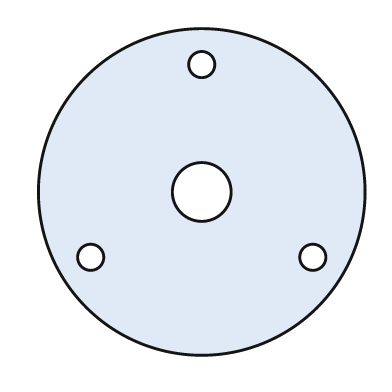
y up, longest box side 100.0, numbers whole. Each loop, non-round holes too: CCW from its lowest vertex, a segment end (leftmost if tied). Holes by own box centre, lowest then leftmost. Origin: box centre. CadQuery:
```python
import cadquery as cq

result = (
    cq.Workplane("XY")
    .moveTo(0.0, 0.0)
    .circle(50.0)
    .moveTo(-34.0, -20.0)
    .circle(4.0)
    .moveTo(34.0, -20.0)
    .circle(4.0)
    .moveTo(0.0, 0.0)
    .circle(9.0)
    .moveTo(0.0, 39.0)
    .circle(4.0)
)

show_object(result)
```